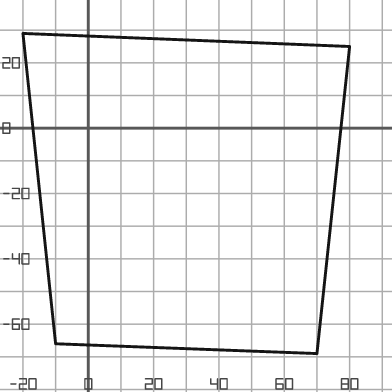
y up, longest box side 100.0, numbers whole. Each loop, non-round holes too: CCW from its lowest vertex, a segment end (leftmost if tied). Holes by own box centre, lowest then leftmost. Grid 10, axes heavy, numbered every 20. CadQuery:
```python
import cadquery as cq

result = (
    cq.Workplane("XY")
    .moveTo(70.0, -69.0)
    .lineTo(80.0, 25.0)
    .lineTo(-20.0, 29.0)
    .lineTo(-10.0, -66.0)
    .close()
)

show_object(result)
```